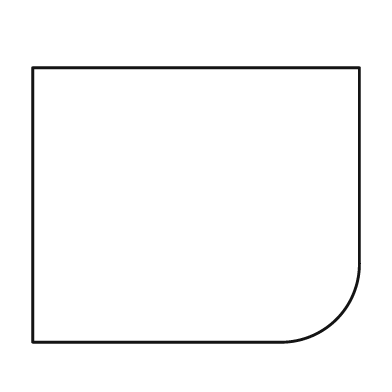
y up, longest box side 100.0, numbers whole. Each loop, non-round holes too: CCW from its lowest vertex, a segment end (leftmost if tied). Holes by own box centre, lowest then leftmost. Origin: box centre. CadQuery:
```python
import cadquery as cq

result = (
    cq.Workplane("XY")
    .moveTo(-50.0, -42.0)
    .lineTo(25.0, -42.0)
    .threePointArc((43.0, -35.0), (50.0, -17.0))
    .lineTo(50.0, 42.0)
    .lineTo(-50.0, 42.0)
    .close()
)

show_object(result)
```